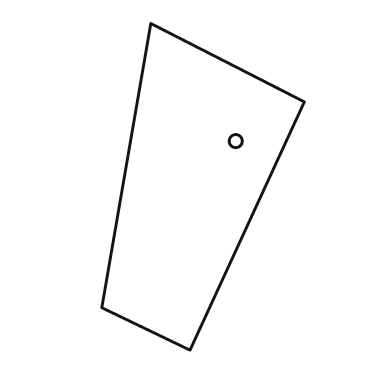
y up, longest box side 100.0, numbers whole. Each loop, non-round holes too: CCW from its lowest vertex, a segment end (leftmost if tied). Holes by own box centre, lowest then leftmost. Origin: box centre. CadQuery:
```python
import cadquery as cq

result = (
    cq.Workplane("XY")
    .moveTo(-4.0, -50.0)
    .lineTo(31.0, 26.0)
    .lineTo(-16.0, 50.0)
    .lineTo(-31.0, -37.0)
    .close()
    .moveTo(10.0, 14.0)
    .circle(2.0)
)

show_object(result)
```